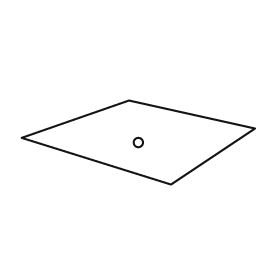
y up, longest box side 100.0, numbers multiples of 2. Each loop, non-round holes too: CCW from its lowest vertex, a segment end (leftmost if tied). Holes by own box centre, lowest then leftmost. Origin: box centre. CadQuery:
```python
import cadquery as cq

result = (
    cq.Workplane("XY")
    .moveTo(14.0, -18.0)
    .lineTo(50.0, 6.0)
    .lineTo(-4.0, 18.0)
    .lineTo(-50.0, 2.0)
    .close()
    .moveTo(0.0, 0.0)
    .circle(2.0)
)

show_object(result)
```